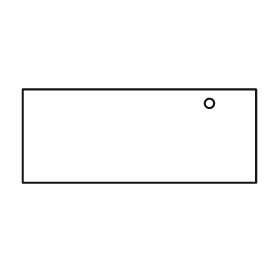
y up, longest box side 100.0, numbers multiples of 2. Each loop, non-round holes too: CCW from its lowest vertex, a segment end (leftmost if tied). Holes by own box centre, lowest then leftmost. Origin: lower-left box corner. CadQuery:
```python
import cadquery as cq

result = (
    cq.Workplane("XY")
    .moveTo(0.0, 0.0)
    .lineTo(100.0, 0.0)
    .lineTo(100.0, 40.0)
    .lineTo(0.0, 40.0)
    .close()
    .moveTo(80.0, 34.0)
    .circle(2.0)
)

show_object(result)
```